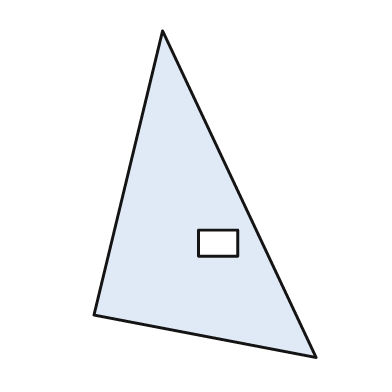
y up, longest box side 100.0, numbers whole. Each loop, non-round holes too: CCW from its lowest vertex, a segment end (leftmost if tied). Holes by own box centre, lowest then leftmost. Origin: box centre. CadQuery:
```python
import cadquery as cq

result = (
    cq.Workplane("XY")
    .moveTo(34.0, -50.0)
    .lineTo(-13.0, 50.0)
    .lineTo(-34.0, -37.0)
    .close()
    .moveTo(-2.0, -19.0)
    .lineTo(10.0, -19.0)
    .lineTo(10.0, -11.0)
    .lineTo(-2.0, -11.0)
    .close()
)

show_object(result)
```